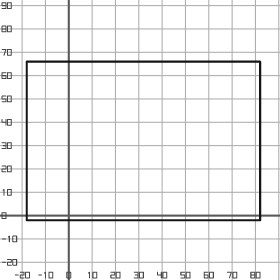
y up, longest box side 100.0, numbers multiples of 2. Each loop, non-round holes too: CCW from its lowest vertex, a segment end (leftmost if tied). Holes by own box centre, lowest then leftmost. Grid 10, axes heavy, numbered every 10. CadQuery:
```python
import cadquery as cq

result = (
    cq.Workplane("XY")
    .moveTo(-18.0, -2.0)
    .lineTo(82.0, -2.0)
    .lineTo(82.0, 66.0)
    .lineTo(-18.0, 66.0)
    .close()
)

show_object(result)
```